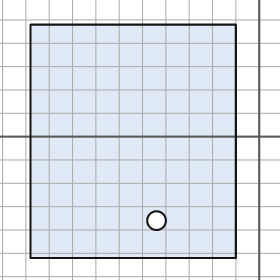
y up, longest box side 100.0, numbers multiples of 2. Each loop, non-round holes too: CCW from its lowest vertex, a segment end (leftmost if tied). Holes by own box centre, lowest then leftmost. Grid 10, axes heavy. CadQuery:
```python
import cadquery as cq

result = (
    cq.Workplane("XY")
    .moveTo(-98.0, -52.0)
    .lineTo(-10.0, -52.0)
    .lineTo(-10.0, 48.0)
    .lineTo(-98.0, 48.0)
    .close()
    .moveTo(-44.0, -36.0)
    .circle(4.0)
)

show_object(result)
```